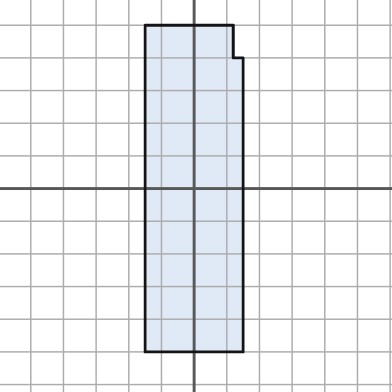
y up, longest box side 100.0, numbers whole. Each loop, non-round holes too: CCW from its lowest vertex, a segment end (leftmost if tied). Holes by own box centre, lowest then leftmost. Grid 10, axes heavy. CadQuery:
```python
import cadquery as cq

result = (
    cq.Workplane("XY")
    .moveTo(-15.0, -50.0)
    .lineTo(15.0, -50.0)
    .lineTo(15.0, 40.0)
    .lineTo(12.0, 40.0)
    .lineTo(12.0, 50.0)
    .lineTo(-15.0, 50.0)
    .close()
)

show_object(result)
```